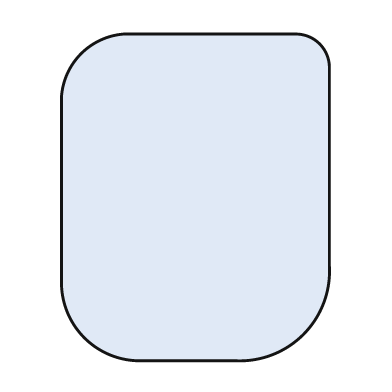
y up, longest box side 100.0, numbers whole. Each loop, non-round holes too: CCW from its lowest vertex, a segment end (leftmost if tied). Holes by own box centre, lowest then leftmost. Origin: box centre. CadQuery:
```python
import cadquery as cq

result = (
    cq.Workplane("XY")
    .moveTo(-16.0, -50.0)
    .lineTo(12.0, -50.0)
    .threePointArc((33.0, -42.0), (41.0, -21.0))
    .lineTo(41.0, 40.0)
    .threePointArc((38.0, 47.0), (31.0, 50.0))
    .lineTo(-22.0, 50.0)
    .threePointArc((-35.0, 44.0), (-41.0, 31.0))
    .lineTo(-41.0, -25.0)
    .threePointArc((-34.0, -43.0), (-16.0, -50.0))
    .close()
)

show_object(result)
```